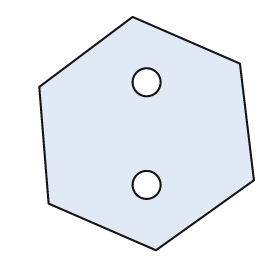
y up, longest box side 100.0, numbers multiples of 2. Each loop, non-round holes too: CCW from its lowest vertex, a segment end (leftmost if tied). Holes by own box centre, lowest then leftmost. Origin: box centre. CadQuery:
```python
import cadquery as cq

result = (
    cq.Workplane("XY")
    .moveTo(4.0, -50.0)
    .lineTo(46.0, -20.0)
    .lineTo(40.0, 30.0)
    .lineTo(-6.0, 50.0)
    .lineTo(-46.0, 20.0)
    .lineTo(-42.0, -30.0)
    .close()
    .moveTo(0.0, -22.0)
    .circle(6.0)
    .moveTo(0.0, 22.0)
    .circle(6.0)
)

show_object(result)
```